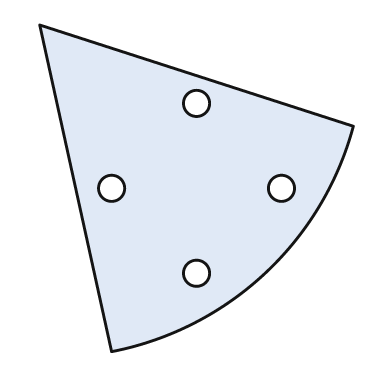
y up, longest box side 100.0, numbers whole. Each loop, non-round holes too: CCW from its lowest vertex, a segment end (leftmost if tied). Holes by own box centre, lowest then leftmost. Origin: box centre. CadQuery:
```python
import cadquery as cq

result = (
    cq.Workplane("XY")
    .moveTo(-26.0, -50.0)
    .threePointArc((21.0, -26.0), (48.0, 19.0))
    .lineTo(-48.0, 50.0)
    .close()
    .moveTo(0.0, -26.0)
    .circle(4.0)
    .moveTo(-26.0, 0.0)
    .circle(4.0)
    .moveTo(26.0, 0.0)
    .circle(4.0)
    .moveTo(0.0, 26.0)
    .circle(4.0)
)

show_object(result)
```